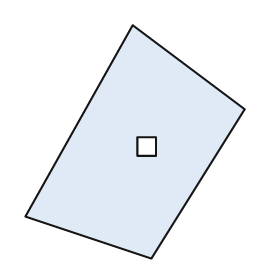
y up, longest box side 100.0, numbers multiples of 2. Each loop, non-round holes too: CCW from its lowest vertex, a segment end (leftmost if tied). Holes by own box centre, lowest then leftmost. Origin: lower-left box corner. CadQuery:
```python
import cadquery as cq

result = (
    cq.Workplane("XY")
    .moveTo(54.0, 0.0)
    .lineTo(94.0, 64.0)
    .lineTo(46.0, 100.0)
    .lineTo(0.0, 18.0)
    .close()
    .moveTo(48.0, 44.0)
    .lineTo(56.0, 44.0)
    .lineTo(56.0, 52.0)
    .lineTo(48.0, 52.0)
    .close()
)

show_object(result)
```